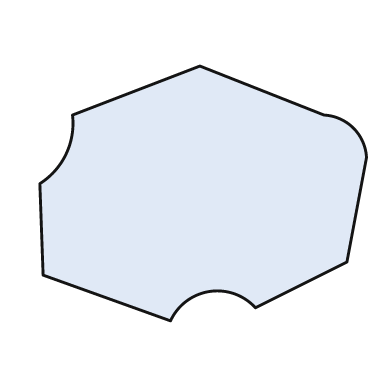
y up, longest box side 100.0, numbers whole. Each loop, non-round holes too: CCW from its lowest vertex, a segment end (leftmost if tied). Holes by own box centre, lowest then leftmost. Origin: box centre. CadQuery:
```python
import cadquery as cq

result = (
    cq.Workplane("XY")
    .moveTo(-10.0, -39.0)
    .threePointArc((2.0, -30.0), (16.0, -35.0))
    .lineTo(44.0, -21.0)
    .lineTo(50.0, 11.0)
    .threePointArc((46.0, 20.0), (37.0, 24.0))
    .lineTo(-1.0, 39.0)
    .lineTo(-40.0, 24.0)
    .threePointArc((-42.0, 12.0), (-50.0, 3.0))
    .lineTo(-49.0, -25.0)
    .close()
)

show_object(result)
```